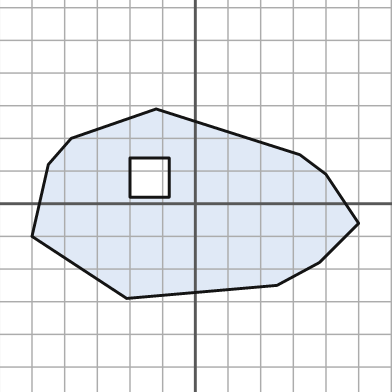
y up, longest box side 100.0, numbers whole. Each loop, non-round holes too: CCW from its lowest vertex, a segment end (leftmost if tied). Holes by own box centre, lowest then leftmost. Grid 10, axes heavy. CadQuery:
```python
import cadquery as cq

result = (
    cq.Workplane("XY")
    .moveTo(-21.0, -29.0)
    .lineTo(25.0, -25.0)
    .lineTo(38.0, -18.0)
    .lineTo(50.0, -6.0)
    .lineTo(40.0, 9.0)
    .lineTo(32.0, 15.0)
    .lineTo(-12.0, 29.0)
    .lineTo(-38.0, 20.0)
    .lineTo(-45.0, 12.0)
    .lineTo(-50.0, -10.0)
    .close()
    .moveTo(-20.0, 2.0)
    .lineTo(-8.0, 2.0)
    .lineTo(-8.0, 14.0)
    .lineTo(-20.0, 14.0)
    .close()
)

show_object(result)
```